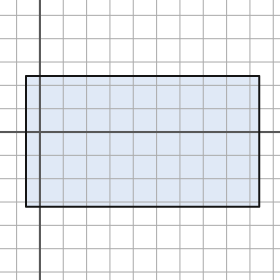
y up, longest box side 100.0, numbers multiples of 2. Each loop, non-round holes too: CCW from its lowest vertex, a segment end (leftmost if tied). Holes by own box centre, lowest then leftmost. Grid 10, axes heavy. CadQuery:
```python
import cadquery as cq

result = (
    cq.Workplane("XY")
    .moveTo(-6.0, -32.0)
    .lineTo(94.0, -32.0)
    .lineTo(94.0, 24.0)
    .lineTo(-6.0, 24.0)
    .close()
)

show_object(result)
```